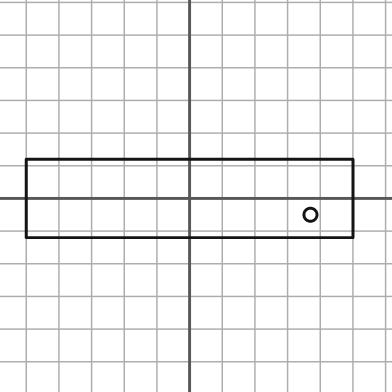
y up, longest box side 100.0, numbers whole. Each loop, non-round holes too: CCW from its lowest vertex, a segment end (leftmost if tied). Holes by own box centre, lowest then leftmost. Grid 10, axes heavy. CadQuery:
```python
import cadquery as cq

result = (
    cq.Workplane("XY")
    .moveTo(-50.0, -12.0)
    .lineTo(50.0, -12.0)
    .lineTo(50.0, 12.0)
    .lineTo(-50.0, 12.0)
    .close()
    .moveTo(37.0, -5.0)
    .circle(2.0)
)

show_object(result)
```